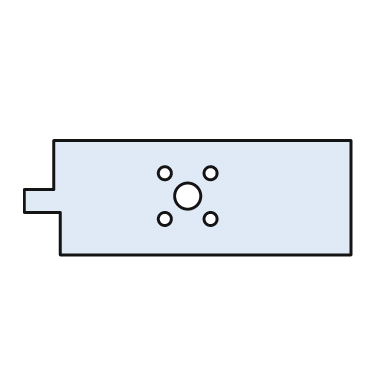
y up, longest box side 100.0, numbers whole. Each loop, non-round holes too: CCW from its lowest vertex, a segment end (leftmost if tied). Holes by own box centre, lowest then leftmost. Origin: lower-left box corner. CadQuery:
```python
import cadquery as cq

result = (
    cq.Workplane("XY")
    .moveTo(11.0, 0.0)
    .lineTo(100.0, 0.0)
    .lineTo(100.0, 35.0)
    .lineTo(9.0, 35.0)
    .lineTo(9.0, 20.0)
    .lineTo(0.0, 20.0)
    .lineTo(0.0, 13.0)
    .lineTo(11.0, 13.0)
    .close()
    .moveTo(43.0, 11.0)
    .circle(2.0)
    .moveTo(57.0, 11.0)
    .circle(2.0)
    .moveTo(50.0, 18.0)
    .circle(4.0)
    .moveTo(43.0, 25.0)
    .circle(2.0)
    .moveTo(57.0, 25.0)
    .circle(2.0)
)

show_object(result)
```